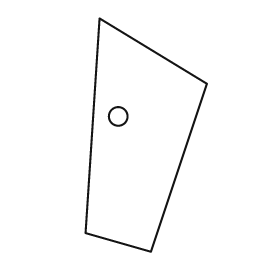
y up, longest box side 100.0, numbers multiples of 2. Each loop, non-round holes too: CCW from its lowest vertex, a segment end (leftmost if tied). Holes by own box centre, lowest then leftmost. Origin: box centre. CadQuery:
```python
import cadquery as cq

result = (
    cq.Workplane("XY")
    .moveTo(2.0, -50.0)
    .lineTo(26.0, 22.0)
    .lineTo(-20.0, 50.0)
    .lineTo(-26.0, -42.0)
    .close()
    .moveTo(-12.0, 8.0)
    .circle(4.0)
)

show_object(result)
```